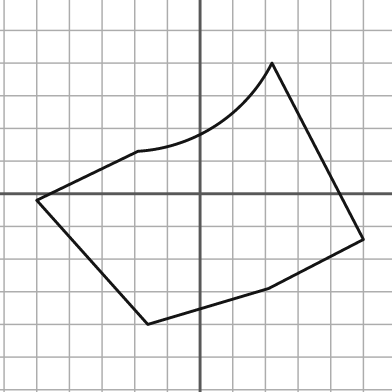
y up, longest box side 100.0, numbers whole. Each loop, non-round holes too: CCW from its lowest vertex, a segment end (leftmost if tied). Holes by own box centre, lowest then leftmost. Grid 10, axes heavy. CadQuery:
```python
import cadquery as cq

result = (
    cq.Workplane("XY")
    .moveTo(-16.0, -40.0)
    .lineTo(21.0, -29.0)
    .lineTo(50.0, -14.0)
    .lineTo(22.0, 40.0)
    .threePointArc((5.0, 21.0), (-19.0, 13.0))
    .lineTo(-50.0, -2.0)
    .close()
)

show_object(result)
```